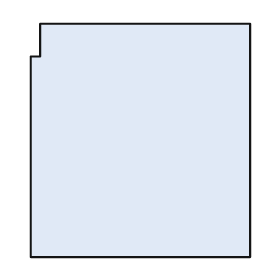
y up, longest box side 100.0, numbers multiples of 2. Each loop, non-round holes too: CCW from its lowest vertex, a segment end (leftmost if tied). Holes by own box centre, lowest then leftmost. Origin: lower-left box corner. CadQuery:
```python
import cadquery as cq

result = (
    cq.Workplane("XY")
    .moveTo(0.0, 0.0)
    .lineTo(94.0, 0.0)
    .lineTo(94.0, 100.0)
    .lineTo(4.0, 100.0)
    .lineTo(4.0, 86.0)
    .lineTo(0.0, 86.0)
    .close()
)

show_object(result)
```